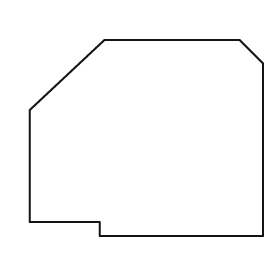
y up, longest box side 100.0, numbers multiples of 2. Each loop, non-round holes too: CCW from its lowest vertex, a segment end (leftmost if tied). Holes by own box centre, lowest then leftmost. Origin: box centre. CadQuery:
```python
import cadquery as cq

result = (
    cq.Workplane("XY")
    .moveTo(-20.0, -42.0)
    .lineTo(50.0, -42.0)
    .lineTo(50.0, 32.0)
    .lineTo(40.0, 42.0)
    .lineTo(-18.0, 42.0)
    .lineTo(-50.0, 12.0)
    .lineTo(-50.0, -36.0)
    .lineTo(-20.0, -36.0)
    .close()
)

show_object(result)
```